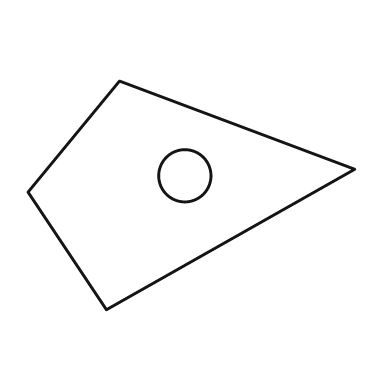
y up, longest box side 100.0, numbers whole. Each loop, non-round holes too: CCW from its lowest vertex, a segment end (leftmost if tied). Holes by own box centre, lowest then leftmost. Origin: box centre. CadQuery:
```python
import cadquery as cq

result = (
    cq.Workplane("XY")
    .moveTo(-26.0, -35.0)
    .lineTo(50.0, 8.0)
    .lineTo(-22.0, 35.0)
    .lineTo(-50.0, 1.0)
    .close()
    .moveTo(-2.0, 6.0)
    .circle(8.0)
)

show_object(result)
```